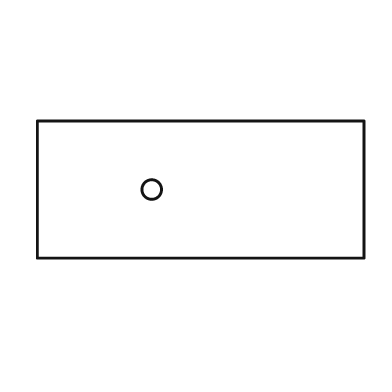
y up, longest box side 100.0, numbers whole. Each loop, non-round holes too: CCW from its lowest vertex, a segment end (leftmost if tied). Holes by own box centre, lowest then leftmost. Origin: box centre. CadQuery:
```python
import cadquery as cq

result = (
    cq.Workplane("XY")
    .moveTo(-50.0, -21.0)
    .lineTo(50.0, -21.0)
    .lineTo(50.0, 21.0)
    .lineTo(-50.0, 21.0)
    .close()
    .moveTo(-15.0, 0.0)
    .circle(3.0)
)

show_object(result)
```